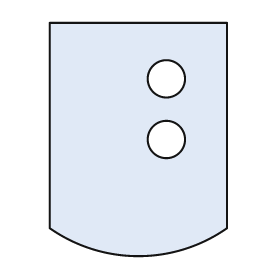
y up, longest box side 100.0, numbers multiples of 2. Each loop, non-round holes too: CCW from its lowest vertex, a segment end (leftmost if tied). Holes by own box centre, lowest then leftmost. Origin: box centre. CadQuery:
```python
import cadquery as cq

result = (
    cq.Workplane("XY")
    .moveTo(-38.0, -38.0)
    .threePointArc((0.0, -50.0), (38.0, -38.0))
    .lineTo(38.0, 50.0)
    .lineTo(-38.0, 50.0)
    .close()
    .moveTo(12.0, 0.0)
    .circle(8.0)
    .moveTo(12.0, 26.0)
    .circle(8.0)
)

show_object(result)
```